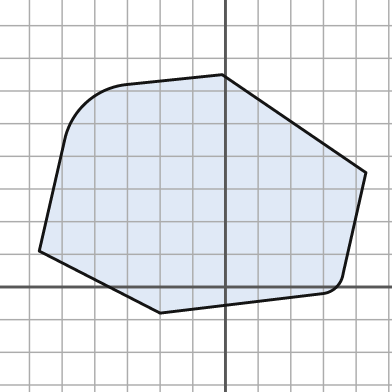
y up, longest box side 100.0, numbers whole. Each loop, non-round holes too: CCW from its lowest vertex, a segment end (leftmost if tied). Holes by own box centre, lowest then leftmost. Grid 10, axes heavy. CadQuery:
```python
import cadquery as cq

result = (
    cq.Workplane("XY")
    .moveTo(-20.0, -8.0)
    .lineTo(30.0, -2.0)
    .threePointArc((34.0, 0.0), (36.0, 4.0))
    .lineTo(43.0, 35.0)
    .lineTo(-1.0, 65.0)
    .lineTo(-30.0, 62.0)
    .threePointArc((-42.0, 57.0), (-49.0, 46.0))
    .lineTo(-57.0, 11.0)
    .close()
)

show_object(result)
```